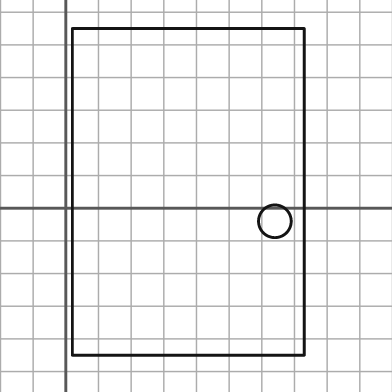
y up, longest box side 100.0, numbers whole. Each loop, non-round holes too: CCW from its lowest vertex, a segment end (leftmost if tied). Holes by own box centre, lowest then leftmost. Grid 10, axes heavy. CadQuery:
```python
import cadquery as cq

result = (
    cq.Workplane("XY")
    .moveTo(2.0, -45.0)
    .lineTo(73.0, -45.0)
    .lineTo(73.0, 55.0)
    .lineTo(2.0, 55.0)
    .close()
    .moveTo(64.0, -4.0)
    .circle(5.0)
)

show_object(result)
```